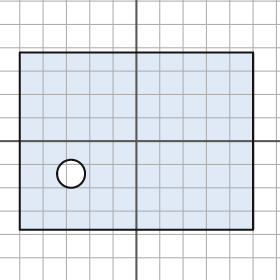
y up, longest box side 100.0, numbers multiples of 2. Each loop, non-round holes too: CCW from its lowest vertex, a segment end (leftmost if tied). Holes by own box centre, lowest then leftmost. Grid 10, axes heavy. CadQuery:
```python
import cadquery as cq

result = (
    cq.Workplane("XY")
    .moveTo(-50.0, -38.0)
    .lineTo(50.0, -38.0)
    .lineTo(50.0, 38.0)
    .lineTo(-50.0, 38.0)
    .close()
    .moveTo(-28.0, -14.0)
    .circle(6.0)
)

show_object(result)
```